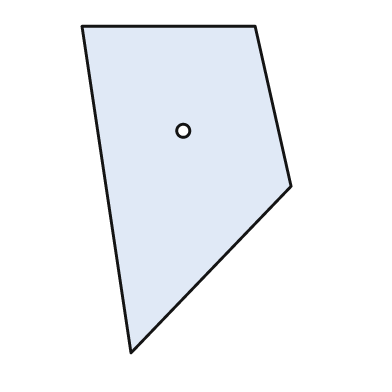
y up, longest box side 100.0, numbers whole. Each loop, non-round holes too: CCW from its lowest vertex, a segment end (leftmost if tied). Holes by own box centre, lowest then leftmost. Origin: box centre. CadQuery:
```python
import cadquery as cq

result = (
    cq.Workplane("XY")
    .moveTo(-17.0, -50.0)
    .lineTo(32.0, 1.0)
    .lineTo(21.0, 50.0)
    .lineTo(-32.0, 50.0)
    .close()
    .moveTo(-1.0, 18.0)
    .circle(2.0)
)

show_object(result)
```